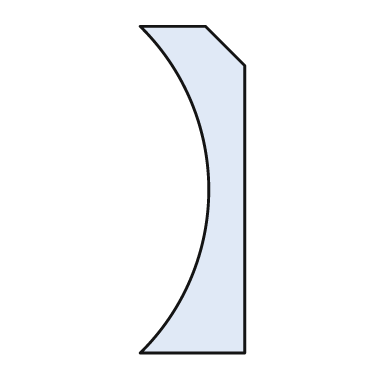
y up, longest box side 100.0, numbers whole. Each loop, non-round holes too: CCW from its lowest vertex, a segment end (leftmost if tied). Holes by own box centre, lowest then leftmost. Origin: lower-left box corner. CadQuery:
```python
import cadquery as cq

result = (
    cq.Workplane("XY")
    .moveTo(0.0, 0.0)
    .lineTo(32.0, 0.0)
    .lineTo(32.0, 88.0)
    .lineTo(20.0, 100.0)
    .lineTo(0.0, 100.0)
    .threePointArc((21.0, 50.0), (0.0, 0.0))
    .close()
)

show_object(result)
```